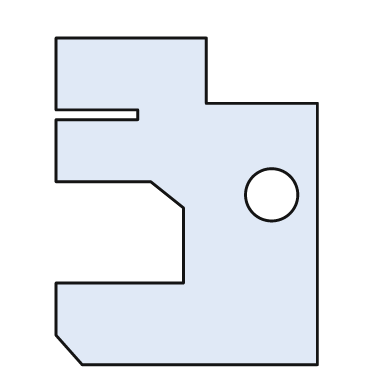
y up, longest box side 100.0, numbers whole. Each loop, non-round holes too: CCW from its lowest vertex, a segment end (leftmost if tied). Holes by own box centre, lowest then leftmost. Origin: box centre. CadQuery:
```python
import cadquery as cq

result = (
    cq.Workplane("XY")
    .moveTo(-32.0, -50.0)
    .lineTo(40.0, -50.0)
    .lineTo(40.0, 30.0)
    .lineTo(6.0, 30.0)
    .lineTo(6.0, 50.0)
    .lineTo(-40.0, 50.0)
    .lineTo(-40.0, 28.0)
    .lineTo(-15.0, 28.0)
    .lineTo(-15.0, 25.0)
    .lineTo(-40.0, 25.0)
    .lineTo(-40.0, 6.0)
    .lineTo(-11.0, 6.0)
    .lineTo(-1.0, -2.0)
    .lineTo(-1.0, -25.0)
    .lineTo(-40.0, -25.0)
    .lineTo(-40.0, -41.0)
    .close()
    .moveTo(26.0, 2.0)
    .circle(8.0)
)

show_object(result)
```